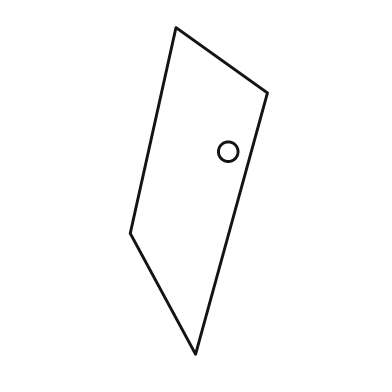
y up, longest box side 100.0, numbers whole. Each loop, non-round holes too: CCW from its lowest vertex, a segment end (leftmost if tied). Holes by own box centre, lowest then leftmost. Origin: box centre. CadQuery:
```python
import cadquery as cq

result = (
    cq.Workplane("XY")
    .moveTo(-1.0, -50.0)
    .lineTo(21.0, 30.0)
    .lineTo(-7.0, 50.0)
    .lineTo(-21.0, -13.0)
    .close()
    .moveTo(9.0, 12.0)
    .circle(3.0)
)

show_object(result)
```